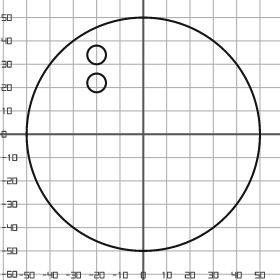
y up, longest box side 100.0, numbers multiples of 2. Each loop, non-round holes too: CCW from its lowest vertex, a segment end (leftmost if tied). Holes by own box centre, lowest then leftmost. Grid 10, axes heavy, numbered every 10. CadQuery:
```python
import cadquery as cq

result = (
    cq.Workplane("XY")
    .moveTo(0.0, 0.0)
    .circle(50.0)
    .moveTo(-20.0, 22.0)
    .circle(4.0)
    .moveTo(-20.0, 34.0)
    .circle(4.0)
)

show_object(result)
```